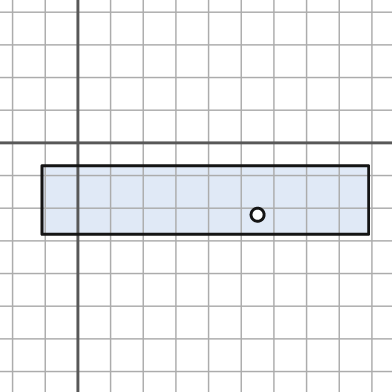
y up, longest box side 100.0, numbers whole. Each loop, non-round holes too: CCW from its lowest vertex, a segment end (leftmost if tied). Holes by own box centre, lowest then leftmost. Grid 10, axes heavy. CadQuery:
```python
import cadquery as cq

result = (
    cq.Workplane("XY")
    .moveTo(-11.0, -28.0)
    .lineTo(89.0, -28.0)
    .lineTo(89.0, -7.0)
    .lineTo(-11.0, -7.0)
    .close()
    .moveTo(55.0, -22.0)
    .circle(2.0)
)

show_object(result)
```